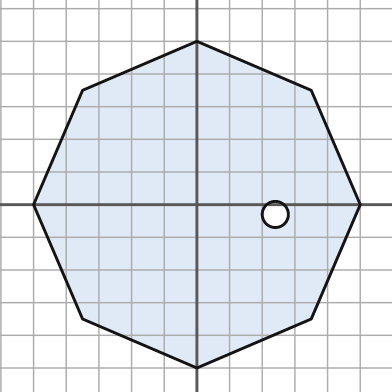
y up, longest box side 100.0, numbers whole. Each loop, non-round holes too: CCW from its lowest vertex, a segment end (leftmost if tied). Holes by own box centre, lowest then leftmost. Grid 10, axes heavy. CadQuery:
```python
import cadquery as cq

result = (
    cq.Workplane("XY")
    .moveTo(0.0, -50.0)
    .lineTo(35.0, -35.0)
    .lineTo(50.0, 0.0)
    .lineTo(35.0, 35.0)
    .lineTo(0.0, 50.0)
    .lineTo(-35.0, 35.0)
    .lineTo(-50.0, 0.0)
    .lineTo(-35.0, -35.0)
    .close()
    .moveTo(24.0, -3.0)
    .circle(4.0)
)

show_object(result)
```